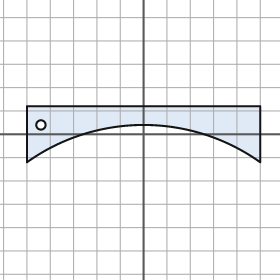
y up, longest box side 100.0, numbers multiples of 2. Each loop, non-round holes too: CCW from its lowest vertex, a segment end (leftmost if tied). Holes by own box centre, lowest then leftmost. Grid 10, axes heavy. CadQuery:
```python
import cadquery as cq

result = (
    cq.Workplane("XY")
    .moveTo(-50.0, -12.0)
    .threePointArc((0.0, 4.0), (50.0, -12.0))
    .lineTo(50.0, 12.0)
    .lineTo(-50.0, 12.0)
    .close()
    .moveTo(-44.0, 4.0)
    .circle(2.0)
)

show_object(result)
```